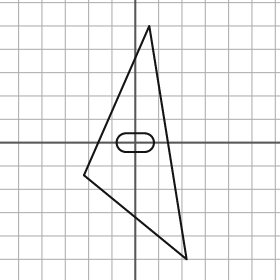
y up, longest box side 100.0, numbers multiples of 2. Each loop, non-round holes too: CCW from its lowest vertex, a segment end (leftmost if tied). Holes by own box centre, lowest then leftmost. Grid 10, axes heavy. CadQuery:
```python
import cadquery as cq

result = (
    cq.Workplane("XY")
    .moveTo(22.0, -50.0)
    .lineTo(6.0, 50.0)
    .lineTo(-22.0, -14.0)
    .close()
    .moveTo(-4.0, -4.0)
    .lineTo(4.0, -4.0)
    .threePointArc((8.0, 0.0), (4.0, 4.0))
    .lineTo(-4.0, 4.0)
    .threePointArc((-8.0, 0.0), (-4.0, -4.0))
    .close()
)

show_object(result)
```